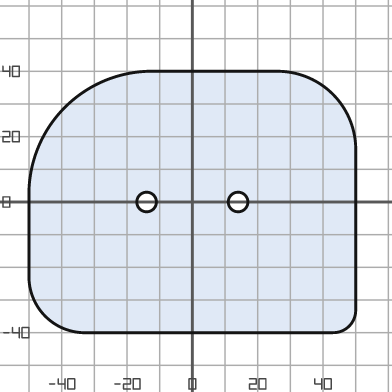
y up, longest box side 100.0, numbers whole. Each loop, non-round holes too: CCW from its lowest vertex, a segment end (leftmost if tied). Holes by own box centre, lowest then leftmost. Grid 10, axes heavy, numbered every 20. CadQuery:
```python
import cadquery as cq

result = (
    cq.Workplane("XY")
    .moveTo(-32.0, -40.0)
    .lineTo(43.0, -40.0)
    .threePointArc((48.0, -38.0), (50.0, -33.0))
    .lineTo(50.0, 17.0)
    .threePointArc((43.0, 33.0), (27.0, 40.0))
    .lineTo(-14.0, 40.0)
    .threePointArc((-39.0, 29.0), (-50.0, 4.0))
    .lineTo(-50.0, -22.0)
    .threePointArc((-45.0, -35.0), (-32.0, -40.0))
    .close()
    .moveTo(-14.0, 0.0)
    .circle(3.0)
    .moveTo(14.0, 0.0)
    .circle(3.0)
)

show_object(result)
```